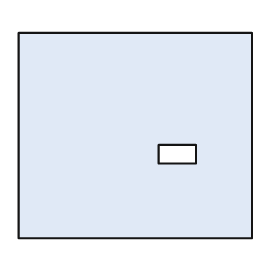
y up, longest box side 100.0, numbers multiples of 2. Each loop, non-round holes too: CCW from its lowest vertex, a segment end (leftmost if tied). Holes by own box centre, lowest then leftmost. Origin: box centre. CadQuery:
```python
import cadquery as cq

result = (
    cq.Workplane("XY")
    .moveTo(-50.0, -44.0)
    .lineTo(50.0, -44.0)
    .lineTo(50.0, 44.0)
    .lineTo(-50.0, 44.0)
    .close()
    .moveTo(10.0, -12.0)
    .lineTo(26.0, -12.0)
    .lineTo(26.0, -4.0)
    .lineTo(10.0, -4.0)
    .close()
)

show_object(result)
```